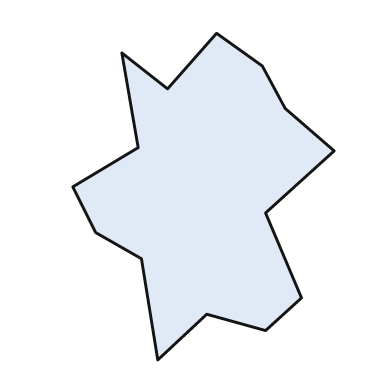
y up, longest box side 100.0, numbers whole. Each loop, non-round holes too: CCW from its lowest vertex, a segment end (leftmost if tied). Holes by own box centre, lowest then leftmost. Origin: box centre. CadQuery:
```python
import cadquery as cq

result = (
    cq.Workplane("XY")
    .moveTo(-14.0, -50.0)
    .lineTo(1.0, -36.0)
    .lineTo(19.0, -41.0)
    .lineTo(30.0, -31.0)
    .lineTo(19.0, -5.0)
    .lineTo(40.0, 14.0)
    .lineTo(25.0, 27.0)
    .lineTo(18.0, 40.0)
    .lineTo(4.0, 50.0)
    .lineTo(-11.0, 33.0)
    .lineTo(-25.0, 44.0)
    .lineTo(-20.0, 15.0)
    .lineTo(-40.0, 3.0)
    .lineTo(-33.0, -11.0)
    .lineTo(-19.0, -19.0)
    .close()
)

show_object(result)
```